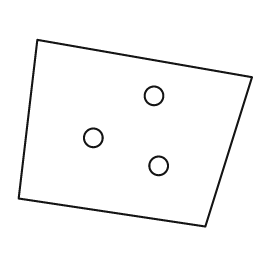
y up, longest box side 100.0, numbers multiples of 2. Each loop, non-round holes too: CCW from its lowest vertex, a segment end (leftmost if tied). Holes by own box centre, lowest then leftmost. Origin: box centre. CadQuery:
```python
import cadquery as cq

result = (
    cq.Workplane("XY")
    .moveTo(30.0, -40.0)
    .lineTo(50.0, 24.0)
    .lineTo(-42.0, 40.0)
    .lineTo(-50.0, -28.0)
    .close()
    .moveTo(10.0, -14.0)
    .circle(4.0)
    .moveTo(-18.0, -2.0)
    .circle(4.0)
    .moveTo(8.0, 16.0)
    .circle(4.0)
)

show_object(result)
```